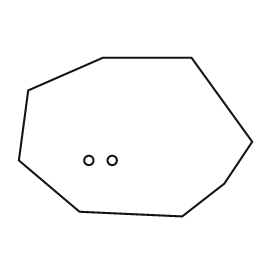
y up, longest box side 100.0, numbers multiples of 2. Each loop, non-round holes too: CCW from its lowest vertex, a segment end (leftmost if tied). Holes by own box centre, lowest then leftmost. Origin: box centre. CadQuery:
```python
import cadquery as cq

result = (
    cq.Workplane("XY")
    .moveTo(20.0, -34.0)
    .lineTo(38.0, -20.0)
    .lineTo(50.0, -2.0)
    .lineTo(24.0, 34.0)
    .lineTo(-14.0, 34.0)
    .lineTo(-46.0, 20.0)
    .lineTo(-50.0, -10.0)
    .lineTo(-24.0, -32.0)
    .close()
    .moveTo(-20.0, -10.0)
    .circle(2.0)
    .moveTo(-10.0, -10.0)
    .circle(2.0)
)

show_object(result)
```